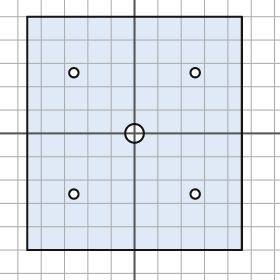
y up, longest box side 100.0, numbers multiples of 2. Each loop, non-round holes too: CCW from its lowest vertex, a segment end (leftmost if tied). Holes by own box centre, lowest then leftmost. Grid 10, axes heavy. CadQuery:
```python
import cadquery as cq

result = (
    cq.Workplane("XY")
    .moveTo(-46.0, -50.0)
    .lineTo(46.0, -50.0)
    .lineTo(46.0, 50.0)
    .lineTo(-46.0, 50.0)
    .close()
    .moveTo(-26.0, -26.0)
    .circle(2.0)
    .moveTo(26.0, -26.0)
    .circle(2.0)
    .moveTo(0.0, 0.0)
    .circle(4.0)
    .moveTo(-26.0, 26.0)
    .circle(2.0)
    .moveTo(26.0, 26.0)
    .circle(2.0)
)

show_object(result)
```